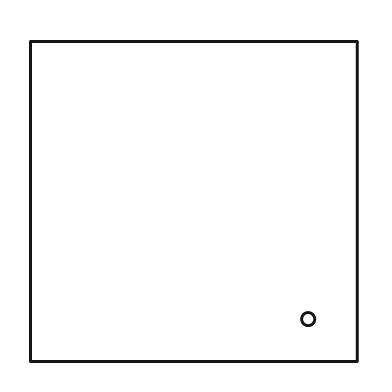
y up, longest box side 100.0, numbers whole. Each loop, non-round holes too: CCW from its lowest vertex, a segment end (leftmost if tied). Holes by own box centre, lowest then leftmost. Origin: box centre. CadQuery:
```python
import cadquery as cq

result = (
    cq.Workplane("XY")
    .moveTo(-50.0, -49.0)
    .lineTo(50.0, -49.0)
    .lineTo(50.0, 49.0)
    .lineTo(-50.0, 49.0)
    .close()
    .moveTo(35.0, -36.0)
    .circle(2.0)
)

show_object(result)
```